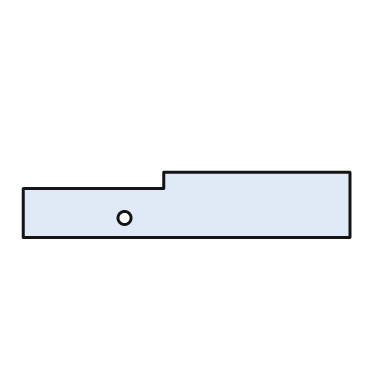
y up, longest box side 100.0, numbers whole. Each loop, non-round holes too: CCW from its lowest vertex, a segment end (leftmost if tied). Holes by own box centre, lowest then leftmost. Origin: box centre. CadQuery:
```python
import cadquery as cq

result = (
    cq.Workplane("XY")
    .moveTo(-50.0, -10.0)
    .lineTo(50.0, -10.0)
    .lineTo(50.0, 10.0)
    .lineTo(-7.0, 10.0)
    .lineTo(-7.0, 5.0)
    .lineTo(-50.0, 5.0)
    .close()
    .moveTo(-19.0, -4.0)
    .circle(2.0)
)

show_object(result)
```